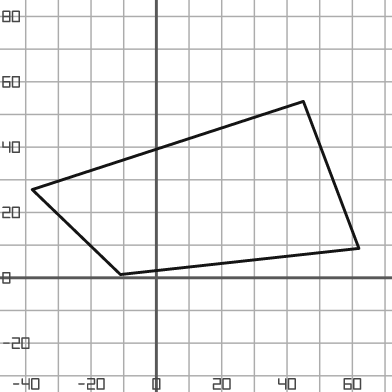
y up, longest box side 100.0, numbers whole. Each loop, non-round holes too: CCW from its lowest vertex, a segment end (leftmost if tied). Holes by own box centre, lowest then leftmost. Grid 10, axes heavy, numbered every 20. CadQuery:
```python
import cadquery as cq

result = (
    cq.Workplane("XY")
    .moveTo(-11.0, 1.0)
    .lineTo(62.0, 9.0)
    .lineTo(45.0, 54.0)
    .lineTo(-38.0, 27.0)
    .close()
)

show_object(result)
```